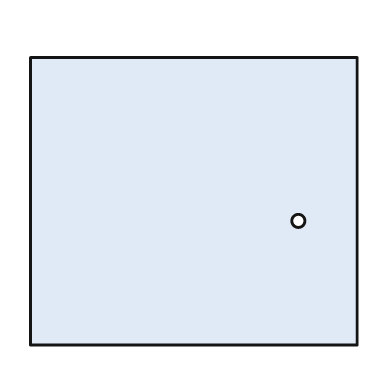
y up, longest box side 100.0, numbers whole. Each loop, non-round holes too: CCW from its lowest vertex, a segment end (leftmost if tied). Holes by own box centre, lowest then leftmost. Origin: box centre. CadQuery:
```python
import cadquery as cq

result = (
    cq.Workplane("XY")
    .moveTo(-50.0, -44.0)
    .lineTo(50.0, -44.0)
    .lineTo(50.0, 44.0)
    .lineTo(-50.0, 44.0)
    .close()
    .moveTo(32.0, -6.0)
    .circle(2.0)
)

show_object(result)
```